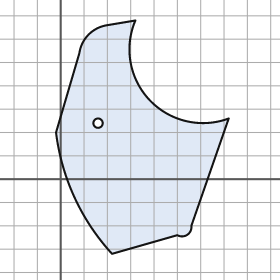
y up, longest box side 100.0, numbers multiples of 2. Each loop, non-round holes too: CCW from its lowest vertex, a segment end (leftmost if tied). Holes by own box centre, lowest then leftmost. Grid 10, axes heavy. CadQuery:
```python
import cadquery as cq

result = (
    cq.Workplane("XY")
    .moveTo(22.0, -32.0)
    .lineTo(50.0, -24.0)
    .threePointArc((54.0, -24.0), (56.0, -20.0))
    .lineTo(72.0, 26.0)
    .threePointArc((38.0, 34.0), (32.0, 68.0))
    .lineTo(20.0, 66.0)
    .threePointArc((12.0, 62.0), (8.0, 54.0))
    .lineTo(-2.0, 20.0)
    .threePointArc((6.0, -8.0), (22.0, -32.0))
    .close()
    .moveTo(16.0, 24.0)
    .circle(2.0)
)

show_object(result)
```